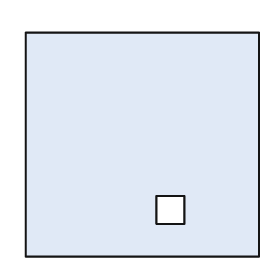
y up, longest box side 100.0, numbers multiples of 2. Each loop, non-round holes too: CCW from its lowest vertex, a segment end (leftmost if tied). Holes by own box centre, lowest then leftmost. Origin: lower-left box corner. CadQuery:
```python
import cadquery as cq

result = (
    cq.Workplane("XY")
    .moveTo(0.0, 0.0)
    .lineTo(100.0, 0.0)
    .lineTo(100.0, 96.0)
    .lineTo(0.0, 96.0)
    .close()
    .moveTo(56.0, 14.0)
    .lineTo(68.0, 14.0)
    .lineTo(68.0, 26.0)
    .lineTo(56.0, 26.0)
    .close()
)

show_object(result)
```